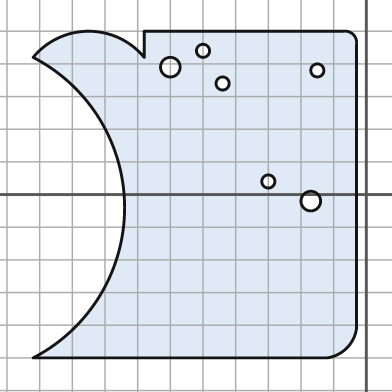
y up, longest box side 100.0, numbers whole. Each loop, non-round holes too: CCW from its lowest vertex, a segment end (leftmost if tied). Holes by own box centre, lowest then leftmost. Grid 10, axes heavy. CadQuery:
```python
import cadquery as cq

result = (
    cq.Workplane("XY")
    .moveTo(-102.0, -50.0)
    .lineTo(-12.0, -50.0)
    .threePointArc((-6.0, -47.0), (-3.0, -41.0))
    .lineTo(-3.0, 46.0)
    .threePointArc((-4.0, 49.0), (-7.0, 50.0))
    .lineTo(-68.0, 50.0)
    .lineTo(-68.0, 42.0)
    .threePointArc((-85.0, 50.0), (-102.0, 42.0))
    .threePointArc((-74.0, -4.0), (-102.0, -50.0))
    .close()
    .moveTo(-17.0, -2.0)
    .circle(3.0)
    .moveTo(-30.0, 4.0)
    .circle(2.0)
    .moveTo(-44.0, 34.0)
    .circle(2.0)
    .moveTo(-15.0, 38.0)
    .circle(2.0)
    .moveTo(-60.0, 39.0)
    .circle(3.0)
    .moveTo(-50.0, 44.0)
    .circle(2.0)
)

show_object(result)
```